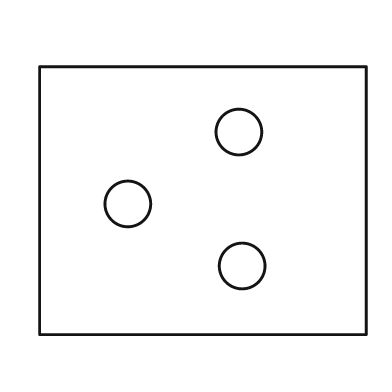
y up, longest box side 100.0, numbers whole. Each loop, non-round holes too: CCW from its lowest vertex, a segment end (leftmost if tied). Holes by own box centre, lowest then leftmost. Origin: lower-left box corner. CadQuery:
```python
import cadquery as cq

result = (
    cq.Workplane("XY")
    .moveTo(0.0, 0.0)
    .lineTo(100.0, 0.0)
    .lineTo(100.0, 82.0)
    .lineTo(0.0, 82.0)
    .close()
    .moveTo(62.0, 21.0)
    .circle(7.0)
    .moveTo(27.0, 40.0)
    .circle(7.0)
    .moveTo(61.0, 62.0)
    .circle(7.0)
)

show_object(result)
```